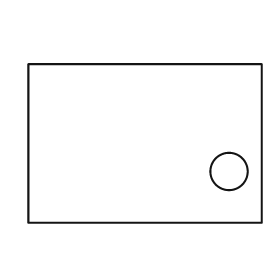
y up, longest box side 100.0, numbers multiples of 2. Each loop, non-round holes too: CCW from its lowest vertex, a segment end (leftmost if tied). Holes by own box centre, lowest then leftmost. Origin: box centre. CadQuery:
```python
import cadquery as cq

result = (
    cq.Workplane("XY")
    .moveTo(-50.0, -34.0)
    .lineTo(50.0, -34.0)
    .lineTo(50.0, 34.0)
    .lineTo(-50.0, 34.0)
    .close()
    .moveTo(36.0, -12.0)
    .circle(8.0)
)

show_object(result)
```